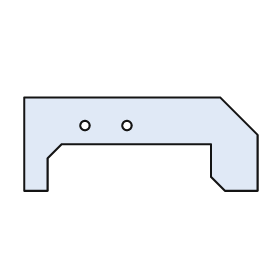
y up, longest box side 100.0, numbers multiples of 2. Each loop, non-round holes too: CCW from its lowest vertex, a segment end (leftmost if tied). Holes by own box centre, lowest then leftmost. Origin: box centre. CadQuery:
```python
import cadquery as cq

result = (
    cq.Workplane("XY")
    .moveTo(-50.0, -20.0)
    .lineTo(-40.0, -20.0)
    .lineTo(-40.0, -6.0)
    .lineTo(-34.0, 0.0)
    .lineTo(30.0, 0.0)
    .lineTo(30.0, -14.0)
    .lineTo(36.0, -20.0)
    .lineTo(50.0, -20.0)
    .lineTo(50.0, 4.0)
    .lineTo(34.0, 20.0)
    .lineTo(-50.0, 20.0)
    .close()
    .moveTo(-24.0, 8.0)
    .circle(2.0)
    .moveTo(-6.0, 8.0)
    .circle(2.0)
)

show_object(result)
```